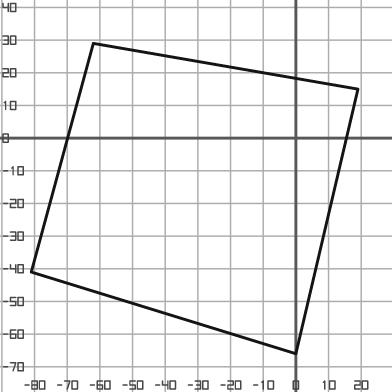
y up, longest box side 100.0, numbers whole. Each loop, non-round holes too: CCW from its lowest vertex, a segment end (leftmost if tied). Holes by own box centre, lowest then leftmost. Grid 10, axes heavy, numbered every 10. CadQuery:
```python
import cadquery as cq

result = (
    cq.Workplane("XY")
    .moveTo(0.0, -66.0)
    .lineTo(19.0, 15.0)
    .lineTo(-62.0, 29.0)
    .lineTo(-81.0, -41.0)
    .close()
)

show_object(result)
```